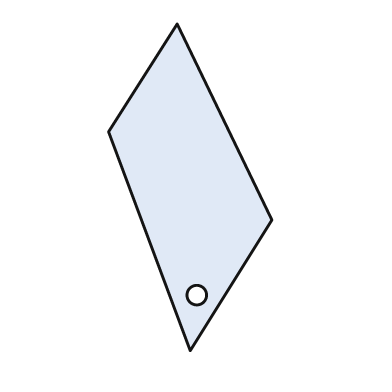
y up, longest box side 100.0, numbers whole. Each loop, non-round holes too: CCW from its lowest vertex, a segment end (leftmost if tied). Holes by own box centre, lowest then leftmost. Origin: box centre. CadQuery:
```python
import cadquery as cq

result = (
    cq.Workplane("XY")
    .moveTo(0.0, -50.0)
    .lineTo(25.0, -10.0)
    .lineTo(-4.0, 50.0)
    .lineTo(-25.0, 17.0)
    .close()
    .moveTo(2.0, -33.0)
    .circle(3.0)
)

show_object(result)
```